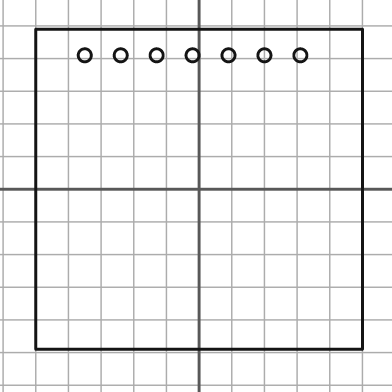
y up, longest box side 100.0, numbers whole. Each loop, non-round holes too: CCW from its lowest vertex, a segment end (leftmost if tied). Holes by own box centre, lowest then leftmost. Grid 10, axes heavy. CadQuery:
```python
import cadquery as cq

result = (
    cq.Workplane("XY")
    .moveTo(-50.0, -49.0)
    .lineTo(50.0, -49.0)
    .lineTo(50.0, 49.0)
    .lineTo(-50.0, 49.0)
    .close()
    .moveTo(-35.0, 41.0)
    .circle(2.0)
    .moveTo(-24.0, 41.0)
    .circle(2.0)
    .moveTo(-13.0, 41.0)
    .circle(2.0)
    .moveTo(-2.0, 41.0)
    .circle(2.0)
    .moveTo(9.0, 41.0)
    .circle(2.0)
    .moveTo(20.0, 41.0)
    .circle(2.0)
    .moveTo(31.0, 41.0)
    .circle(2.0)
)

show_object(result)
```